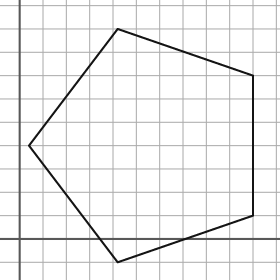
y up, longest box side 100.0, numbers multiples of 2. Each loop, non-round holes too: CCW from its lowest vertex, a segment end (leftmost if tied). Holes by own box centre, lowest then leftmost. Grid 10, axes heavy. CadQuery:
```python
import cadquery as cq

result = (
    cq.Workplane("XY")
    .moveTo(42.0, -10.0)
    .lineTo(100.0, 10.0)
    .lineTo(100.0, 70.0)
    .lineTo(42.0, 90.0)
    .lineTo(4.0, 40.0)
    .close()
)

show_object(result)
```